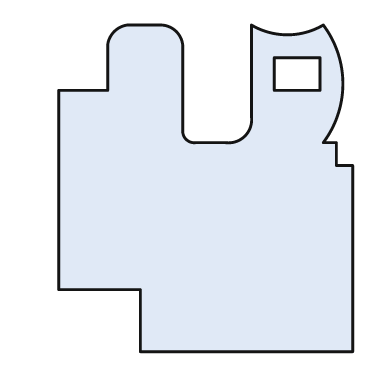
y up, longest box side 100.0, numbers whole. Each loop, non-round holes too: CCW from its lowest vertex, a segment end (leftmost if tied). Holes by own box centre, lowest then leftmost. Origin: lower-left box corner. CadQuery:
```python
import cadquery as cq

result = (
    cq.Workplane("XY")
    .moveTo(25.0, 0.0)
    .lineTo(90.0, 0.0)
    .lineTo(90.0, 57.0)
    .lineTo(85.0, 57.0)
    .lineTo(85.0, 64.0)
    .lineTo(81.0, 64.0)
    .threePointArc((87.0, 82.0), (81.0, 100.0))
    .threePointArc((70.0, 97.0), (59.0, 100.0))
    .lineTo(59.0, 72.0)
    .threePointArc((57.0, 66.0), (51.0, 64.0))
    .lineTo(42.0, 64.0)
    .threePointArc((39.0, 65.0), (38.0, 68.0))
    .lineTo(38.0, 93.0)
    .threePointArc((36.0, 98.0), (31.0, 100.0))
    .lineTo(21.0, 100.0)
    .threePointArc((17.0, 98.0), (15.0, 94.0))
    .lineTo(15.0, 80.0)
    .lineTo(0.0, 80.0)
    .lineTo(0.0, 19.0)
    .lineTo(25.0, 19.0)
    .close()
    .moveTo(66.0, 80.0)
    .lineTo(80.0, 80.0)
    .lineTo(80.0, 90.0)
    .lineTo(66.0, 90.0)
    .close()
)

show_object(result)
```